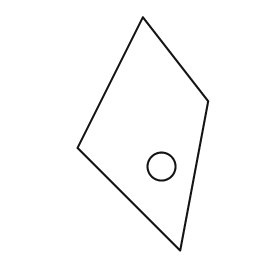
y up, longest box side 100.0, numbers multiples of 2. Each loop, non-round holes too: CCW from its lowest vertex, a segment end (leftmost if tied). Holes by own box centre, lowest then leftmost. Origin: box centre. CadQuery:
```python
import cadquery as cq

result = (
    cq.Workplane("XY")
    .moveTo(16.0, -50.0)
    .lineTo(28.0, 14.0)
    .lineTo(0.0, 50.0)
    .lineTo(-28.0, -6.0)
    .close()
    .moveTo(8.0, -14.0)
    .circle(6.0)
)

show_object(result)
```